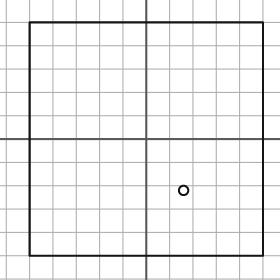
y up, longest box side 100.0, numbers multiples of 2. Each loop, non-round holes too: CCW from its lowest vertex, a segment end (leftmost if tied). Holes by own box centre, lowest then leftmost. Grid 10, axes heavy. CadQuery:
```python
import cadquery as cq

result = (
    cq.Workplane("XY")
    .moveTo(-50.0, -50.0)
    .lineTo(50.0, -50.0)
    .lineTo(50.0, 50.0)
    .lineTo(-50.0, 50.0)
    .close()
    .moveTo(16.0, -22.0)
    .circle(2.0)
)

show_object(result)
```